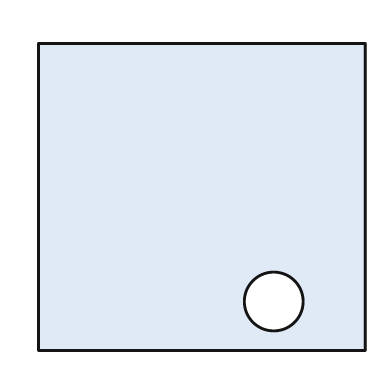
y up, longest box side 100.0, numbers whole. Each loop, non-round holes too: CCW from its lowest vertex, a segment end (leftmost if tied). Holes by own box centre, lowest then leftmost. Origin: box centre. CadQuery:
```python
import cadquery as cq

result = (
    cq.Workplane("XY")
    .moveTo(-50.0, -47.0)
    .lineTo(50.0, -47.0)
    .lineTo(50.0, 47.0)
    .lineTo(-50.0, 47.0)
    .close()
    .moveTo(22.0, -32.0)
    .circle(9.0)
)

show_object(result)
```